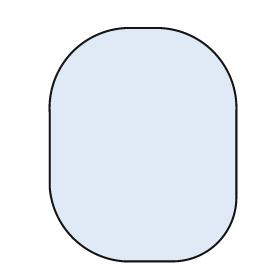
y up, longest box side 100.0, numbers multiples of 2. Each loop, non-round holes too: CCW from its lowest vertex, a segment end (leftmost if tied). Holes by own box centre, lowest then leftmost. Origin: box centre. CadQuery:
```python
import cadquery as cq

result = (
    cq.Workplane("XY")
    .moveTo(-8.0, -50.0)
    .lineTo(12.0, -50.0)
    .threePointArc((32.0, -42.0), (40.0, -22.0))
    .lineTo(40.0, 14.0)
    .threePointArc((30.0, 40.0), (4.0, 50.0))
    .lineTo(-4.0, 50.0)
    .threePointArc((-30.0, 40.0), (-40.0, 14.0))
    .lineTo(-40.0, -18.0)
    .threePointArc((-30.0, -40.0), (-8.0, -50.0))
    .close()
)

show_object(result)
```